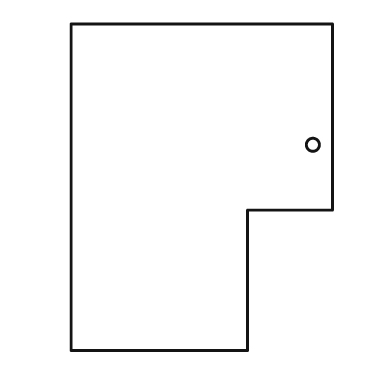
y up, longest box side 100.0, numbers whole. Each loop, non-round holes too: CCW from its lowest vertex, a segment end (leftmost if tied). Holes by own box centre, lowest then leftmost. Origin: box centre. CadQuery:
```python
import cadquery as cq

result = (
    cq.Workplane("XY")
    .moveTo(-40.0, -50.0)
    .lineTo(14.0, -50.0)
    .lineTo(14.0, -7.0)
    .lineTo(40.0, -7.0)
    .lineTo(40.0, 50.0)
    .lineTo(-40.0, 50.0)
    .close()
    .moveTo(34.0, 13.0)
    .circle(2.0)
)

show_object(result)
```